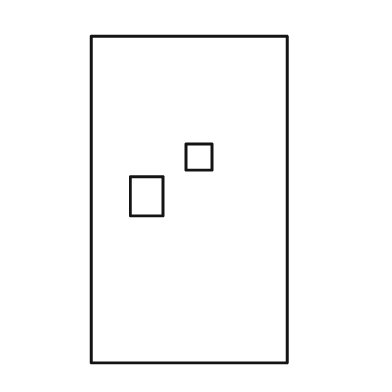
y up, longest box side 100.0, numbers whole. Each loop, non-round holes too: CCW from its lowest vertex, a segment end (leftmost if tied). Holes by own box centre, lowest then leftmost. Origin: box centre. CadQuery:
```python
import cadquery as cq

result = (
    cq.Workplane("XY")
    .moveTo(-30.0, -50.0)
    .lineTo(30.0, -50.0)
    .lineTo(30.0, 50.0)
    .lineTo(-30.0, 50.0)
    .close()
    .moveTo(-18.0, -5.0)
    .lineTo(-8.0, -5.0)
    .lineTo(-8.0, 7.0)
    .lineTo(-18.0, 7.0)
    .close()
    .moveTo(-1.0, 9.0)
    .lineTo(7.0, 9.0)
    .lineTo(7.0, 17.0)
    .lineTo(-1.0, 17.0)
    .close()
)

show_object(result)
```